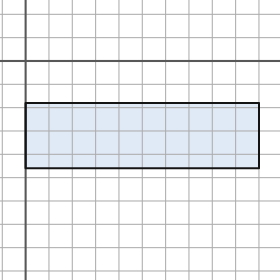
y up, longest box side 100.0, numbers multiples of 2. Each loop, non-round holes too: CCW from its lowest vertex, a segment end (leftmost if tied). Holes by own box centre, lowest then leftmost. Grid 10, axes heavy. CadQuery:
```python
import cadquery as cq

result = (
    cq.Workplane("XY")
    .moveTo(0.0, -46.0)
    .lineTo(100.0, -46.0)
    .lineTo(100.0, -18.0)
    .lineTo(0.0, -18.0)
    .close()
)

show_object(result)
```